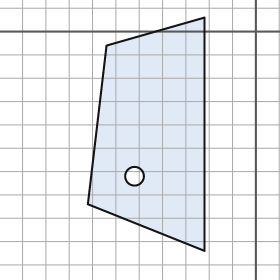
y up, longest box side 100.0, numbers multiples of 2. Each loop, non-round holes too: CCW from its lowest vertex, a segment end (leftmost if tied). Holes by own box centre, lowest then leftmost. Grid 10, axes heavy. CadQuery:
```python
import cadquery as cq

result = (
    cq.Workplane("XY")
    .moveTo(-22.0, -94.0)
    .lineTo(-22.0, 6.0)
    .lineTo(-64.0, -6.0)
    .lineTo(-72.0, -74.0)
    .close()
    .moveTo(-52.0, -62.0)
    .circle(4.0)
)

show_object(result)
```